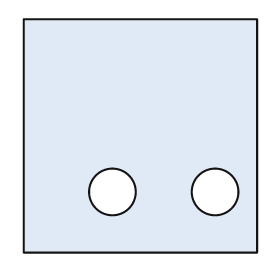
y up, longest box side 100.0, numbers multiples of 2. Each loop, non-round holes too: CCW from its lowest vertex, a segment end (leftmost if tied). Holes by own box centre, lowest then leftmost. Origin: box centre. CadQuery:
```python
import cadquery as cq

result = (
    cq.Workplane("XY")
    .moveTo(-50.0, -50.0)
    .lineTo(50.0, -50.0)
    .lineTo(50.0, 50.0)
    .lineTo(-50.0, 50.0)
    .close()
    .moveTo(-12.0, -24.0)
    .circle(10.0)
    .moveTo(32.0, -24.0)
    .circle(10.0)
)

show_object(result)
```